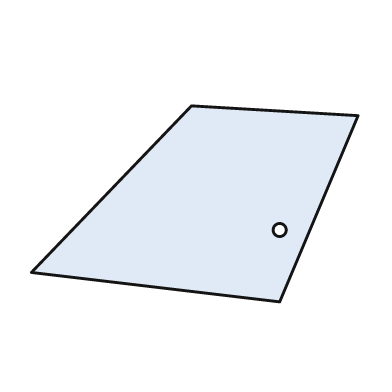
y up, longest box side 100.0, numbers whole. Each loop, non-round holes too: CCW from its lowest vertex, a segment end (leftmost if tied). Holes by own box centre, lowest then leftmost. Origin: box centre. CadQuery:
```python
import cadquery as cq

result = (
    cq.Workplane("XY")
    .moveTo(26.0, -30.0)
    .lineTo(50.0, 27.0)
    .lineTo(-1.0, 30.0)
    .lineTo(-50.0, -21.0)
    .close()
    .moveTo(26.0, -8.0)
    .circle(2.0)
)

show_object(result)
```